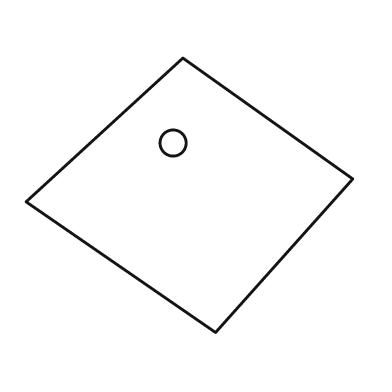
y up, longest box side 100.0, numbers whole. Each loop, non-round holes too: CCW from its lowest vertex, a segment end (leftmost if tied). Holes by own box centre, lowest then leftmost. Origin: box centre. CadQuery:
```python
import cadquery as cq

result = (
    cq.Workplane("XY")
    .moveTo(8.0, -42.0)
    .lineTo(50.0, 5.0)
    .lineTo(-2.0, 42.0)
    .lineTo(-50.0, -2.0)
    .close()
    .moveTo(-5.0, 16.0)
    .circle(4.0)
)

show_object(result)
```